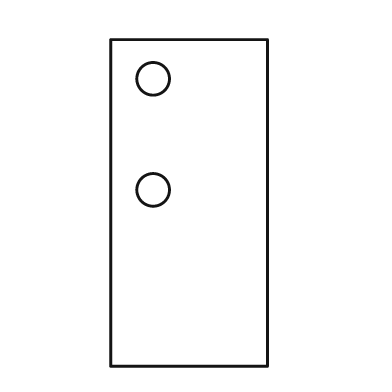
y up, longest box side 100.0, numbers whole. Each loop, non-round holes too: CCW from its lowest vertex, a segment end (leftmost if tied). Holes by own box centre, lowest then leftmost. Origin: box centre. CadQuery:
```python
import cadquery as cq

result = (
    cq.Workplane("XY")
    .moveTo(-24.0, -50.0)
    .lineTo(24.0, -50.0)
    .lineTo(24.0, 50.0)
    .lineTo(-24.0, 50.0)
    .close()
    .moveTo(-11.0, 4.0)
    .circle(5.0)
    .moveTo(-11.0, 38.0)
    .circle(5.0)
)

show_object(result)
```